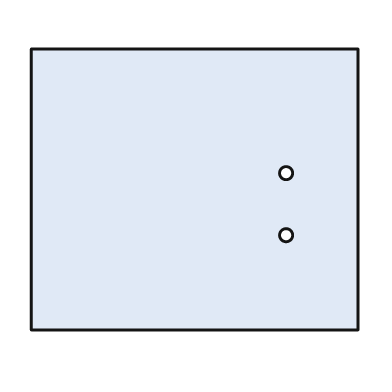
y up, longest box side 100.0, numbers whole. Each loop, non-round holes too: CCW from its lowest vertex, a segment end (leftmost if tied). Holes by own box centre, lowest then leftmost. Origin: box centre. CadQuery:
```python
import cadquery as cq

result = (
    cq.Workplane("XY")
    .moveTo(-50.0, -43.0)
    .lineTo(50.0, -43.0)
    .lineTo(50.0, 43.0)
    .lineTo(-50.0, 43.0)
    .close()
    .moveTo(28.0, -14.0)
    .circle(2.0)
    .moveTo(28.0, 5.0)
    .circle(2.0)
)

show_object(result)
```